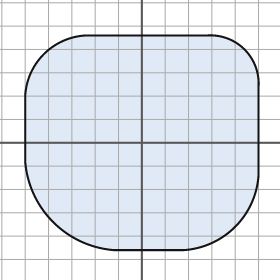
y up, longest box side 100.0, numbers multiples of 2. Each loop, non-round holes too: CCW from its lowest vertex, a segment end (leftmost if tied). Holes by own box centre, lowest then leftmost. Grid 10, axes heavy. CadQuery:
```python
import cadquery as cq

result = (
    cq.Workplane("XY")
    .moveTo(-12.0, -46.0)
    .lineTo(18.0, -46.0)
    .threePointArc((40.0, -36.0), (50.0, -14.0))
    .lineTo(50.0, 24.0)
    .threePointArc((44.0, 40.0), (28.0, 46.0))
    .lineTo(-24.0, 46.0)
    .threePointArc((-42.0, 38.0), (-50.0, 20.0))
    .lineTo(-50.0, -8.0)
    .threePointArc((-38.0, -34.0), (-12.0, -46.0))
    .close()
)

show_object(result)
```